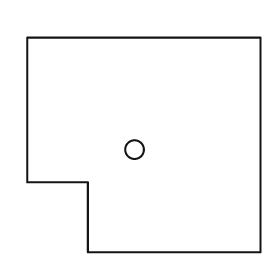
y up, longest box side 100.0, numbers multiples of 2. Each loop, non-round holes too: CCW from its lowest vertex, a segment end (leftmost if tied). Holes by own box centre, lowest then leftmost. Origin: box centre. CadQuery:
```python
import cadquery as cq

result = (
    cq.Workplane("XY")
    .moveTo(-24.0, -46.0)
    .lineTo(50.0, -46.0)
    .lineTo(50.0, 46.0)
    .lineTo(-50.0, 46.0)
    .lineTo(-50.0, -16.0)
    .lineTo(-24.0, -16.0)
    .close()
    .moveTo(-4.0, -2.0)
    .circle(4.0)
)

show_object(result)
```